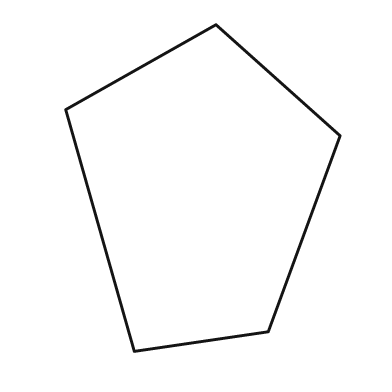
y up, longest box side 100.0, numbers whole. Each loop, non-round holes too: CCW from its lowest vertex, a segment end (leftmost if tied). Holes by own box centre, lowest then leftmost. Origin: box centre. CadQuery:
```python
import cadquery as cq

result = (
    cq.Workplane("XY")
    .moveTo(-21.0, -50.0)
    .lineTo(20.0, -44.0)
    .lineTo(42.0, 16.0)
    .lineTo(4.0, 50.0)
    .lineTo(-42.0, 24.0)
    .close()
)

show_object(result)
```